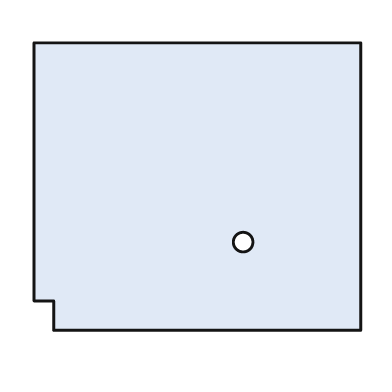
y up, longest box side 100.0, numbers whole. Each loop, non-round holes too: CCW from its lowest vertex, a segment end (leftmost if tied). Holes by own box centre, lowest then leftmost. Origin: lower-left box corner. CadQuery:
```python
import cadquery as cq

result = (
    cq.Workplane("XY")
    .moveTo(6.0, 0.0)
    .lineTo(100.0, 0.0)
    .lineTo(100.0, 88.0)
    .lineTo(0.0, 88.0)
    .lineTo(0.0, 9.0)
    .lineTo(6.0, 9.0)
    .close()
    .moveTo(64.0, 27.0)
    .circle(3.0)
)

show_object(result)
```